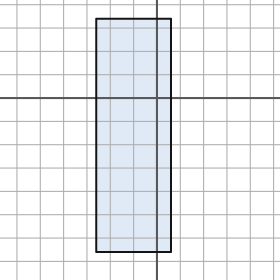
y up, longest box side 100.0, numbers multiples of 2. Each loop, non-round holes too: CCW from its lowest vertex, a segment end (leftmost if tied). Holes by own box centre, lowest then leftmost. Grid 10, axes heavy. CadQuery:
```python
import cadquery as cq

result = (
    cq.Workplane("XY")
    .moveTo(-26.0, -66.0)
    .lineTo(6.0, -66.0)
    .lineTo(6.0, 34.0)
    .lineTo(-26.0, 34.0)
    .close()
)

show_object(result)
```